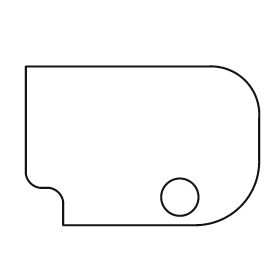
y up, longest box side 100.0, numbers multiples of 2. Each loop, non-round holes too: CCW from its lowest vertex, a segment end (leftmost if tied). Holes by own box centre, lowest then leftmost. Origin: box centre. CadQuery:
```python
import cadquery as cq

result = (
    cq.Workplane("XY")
    .moveTo(-34.0, -34.0)
    .lineTo(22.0, -34.0)
    .threePointArc((42.0, -26.0), (50.0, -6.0))
    .lineTo(50.0, 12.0)
    .threePointArc((44.0, 28.0), (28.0, 34.0))
    .lineTo(-50.0, 34.0)
    .lineTo(-50.0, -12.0)
    .threePointArc((-48.0, -16.0), (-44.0, -18.0))
    .lineTo(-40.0, -18.0)
    .threePointArc((-36.0, -20.0), (-34.0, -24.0))
    .close()
    .moveTo(16.0, -22.0)
    .circle(8.0)
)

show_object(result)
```